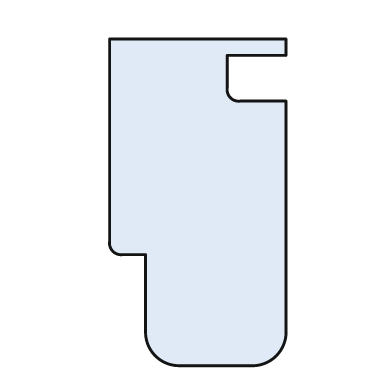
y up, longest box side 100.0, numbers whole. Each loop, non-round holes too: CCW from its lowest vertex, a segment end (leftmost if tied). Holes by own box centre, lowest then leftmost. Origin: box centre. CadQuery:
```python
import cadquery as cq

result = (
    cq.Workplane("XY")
    .moveTo(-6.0, -50.0)
    .lineTo(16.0, -50.0)
    .threePointArc((24.0, -47.0), (27.0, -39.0))
    .lineTo(27.0, 31.0)
    .lineTo(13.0, 31.0)
    .threePointArc((10.0, 32.0), (9.0, 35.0))
    .lineTo(9.0, 45.0)
    .lineTo(27.0, 45.0)
    .lineTo(27.0, 50.0)
    .lineTo(-27.0, 50.0)
    .lineTo(-27.0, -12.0)
    .threePointArc((-26.0, -15.0), (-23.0, -16.0))
    .lineTo(-16.0, -16.0)
    .lineTo(-16.0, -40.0)
    .threePointArc((-13.0, -47.0), (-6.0, -50.0))
    .close()
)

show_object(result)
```